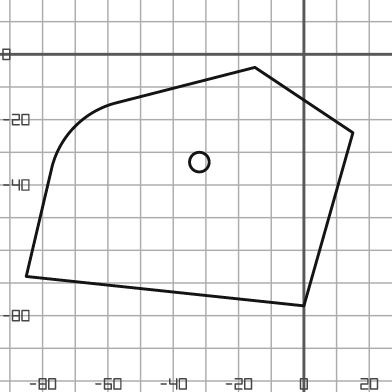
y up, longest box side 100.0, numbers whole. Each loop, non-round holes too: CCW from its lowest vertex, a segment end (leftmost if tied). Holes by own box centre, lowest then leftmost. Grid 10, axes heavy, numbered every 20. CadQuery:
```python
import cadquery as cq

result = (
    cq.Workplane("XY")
    .moveTo(0.0, -77.0)
    .lineTo(15.0, -24.0)
    .lineTo(-15.0, -4.0)
    .lineTo(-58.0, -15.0)
    .threePointArc((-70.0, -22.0), (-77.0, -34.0))
    .lineTo(-85.0, -68.0)
    .close()
    .moveTo(-32.0, -33.0)
    .circle(3.0)
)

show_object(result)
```